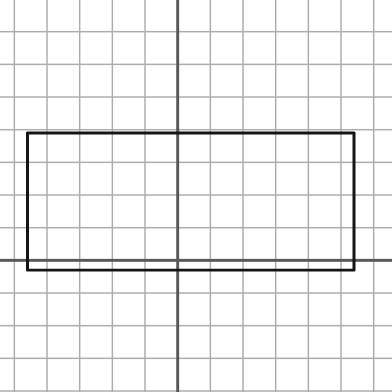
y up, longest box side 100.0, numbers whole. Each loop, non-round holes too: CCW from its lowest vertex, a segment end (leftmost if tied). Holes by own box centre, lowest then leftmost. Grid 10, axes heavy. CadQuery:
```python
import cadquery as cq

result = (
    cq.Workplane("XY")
    .moveTo(-46.0, -3.0)
    .lineTo(54.0, -3.0)
    .lineTo(54.0, 39.0)
    .lineTo(-46.0, 39.0)
    .close()
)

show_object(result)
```